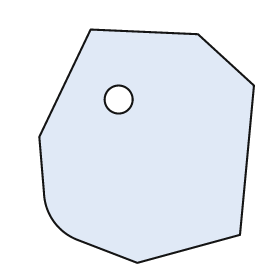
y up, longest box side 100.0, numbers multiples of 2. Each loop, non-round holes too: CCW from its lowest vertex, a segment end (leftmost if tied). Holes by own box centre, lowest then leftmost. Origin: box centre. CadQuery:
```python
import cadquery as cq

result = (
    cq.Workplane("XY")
    .moveTo(-4.0, -50.0)
    .lineTo(40.0, -38.0)
    .lineTo(46.0, 26.0)
    .lineTo(22.0, 48.0)
    .lineTo(-24.0, 50.0)
    .lineTo(-46.0, 4.0)
    .lineTo(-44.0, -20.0)
    .threePointArc((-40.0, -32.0), (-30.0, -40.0))
    .close()
    .moveTo(-12.0, 20.0)
    .circle(6.0)
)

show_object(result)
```